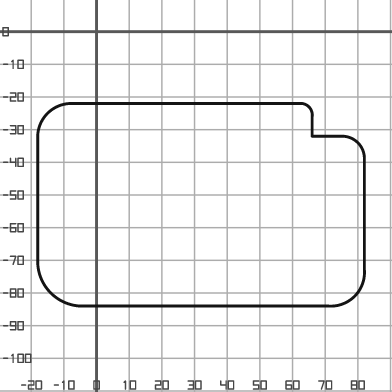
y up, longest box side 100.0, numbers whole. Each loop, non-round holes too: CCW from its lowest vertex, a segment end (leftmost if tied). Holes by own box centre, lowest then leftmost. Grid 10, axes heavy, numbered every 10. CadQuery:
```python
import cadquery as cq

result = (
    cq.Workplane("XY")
    .moveTo(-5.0, -84.0)
    .lineTo(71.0, -84.0)
    .threePointArc((79.0, -81.0), (82.0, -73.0))
    .lineTo(82.0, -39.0)
    .threePointArc((80.0, -34.0), (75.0, -32.0))
    .lineTo(66.0, -32.0)
    .lineTo(66.0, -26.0)
    .threePointArc((65.0, -23.0), (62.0, -22.0))
    .lineTo(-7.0, -22.0)
    .threePointArc((-15.0, -25.0), (-18.0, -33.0))
    .lineTo(-18.0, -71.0)
    .threePointArc((-14.0, -80.0), (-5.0, -84.0))
    .close()
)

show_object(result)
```